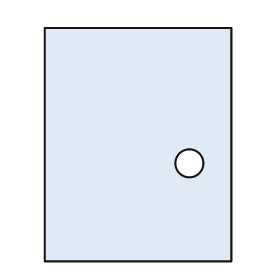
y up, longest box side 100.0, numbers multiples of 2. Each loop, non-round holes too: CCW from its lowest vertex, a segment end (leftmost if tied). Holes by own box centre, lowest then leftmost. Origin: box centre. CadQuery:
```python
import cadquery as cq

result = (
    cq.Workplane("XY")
    .moveTo(-40.0, -50.0)
    .lineTo(40.0, -50.0)
    .lineTo(40.0, 50.0)
    .lineTo(-40.0, 50.0)
    .close()
    .moveTo(22.0, -8.0)
    .circle(6.0)
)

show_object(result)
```